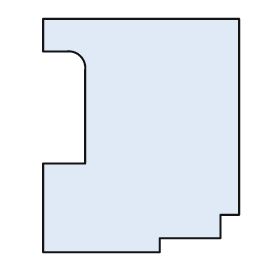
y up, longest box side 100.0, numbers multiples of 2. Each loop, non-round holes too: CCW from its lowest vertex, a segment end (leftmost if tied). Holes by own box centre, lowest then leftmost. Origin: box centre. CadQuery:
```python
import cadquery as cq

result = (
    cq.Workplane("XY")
    .moveTo(-42.0, -50.0)
    .lineTo(8.0, -50.0)
    .lineTo(8.0, -44.0)
    .lineTo(34.0, -44.0)
    .lineTo(34.0, -34.0)
    .lineTo(42.0, -34.0)
    .lineTo(42.0, 50.0)
    .lineTo(-42.0, 50.0)
    .lineTo(-42.0, 36.0)
    .lineTo(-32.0, 36.0)
    .threePointArc((-26.0, 34.0), (-24.0, 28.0))
    .lineTo(-24.0, -12.0)
    .lineTo(-42.0, -12.0)
    .close()
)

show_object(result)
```